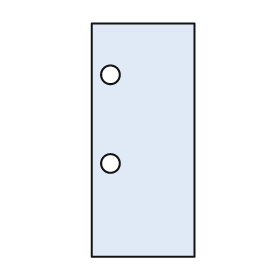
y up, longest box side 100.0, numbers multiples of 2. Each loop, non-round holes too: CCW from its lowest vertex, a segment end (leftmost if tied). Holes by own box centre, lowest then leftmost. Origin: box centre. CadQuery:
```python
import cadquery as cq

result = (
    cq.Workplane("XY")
    .moveTo(-22.0, -50.0)
    .lineTo(22.0, -50.0)
    .lineTo(22.0, 50.0)
    .lineTo(-22.0, 50.0)
    .close()
    .moveTo(-14.0, -10.0)
    .circle(4.0)
    .moveTo(-14.0, 28.0)
    .circle(4.0)
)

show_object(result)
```